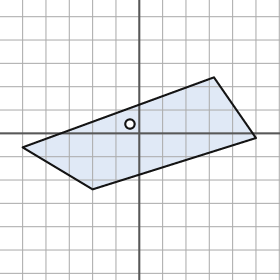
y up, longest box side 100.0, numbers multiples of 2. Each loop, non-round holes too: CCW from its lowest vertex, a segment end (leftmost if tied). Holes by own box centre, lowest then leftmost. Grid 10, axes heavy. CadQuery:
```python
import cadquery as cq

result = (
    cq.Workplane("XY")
    .moveTo(-20.0, -24.0)
    .lineTo(50.0, -2.0)
    .lineTo(32.0, 24.0)
    .lineTo(-50.0, -6.0)
    .close()
    .moveTo(-4.0, 4.0)
    .circle(2.0)
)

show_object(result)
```